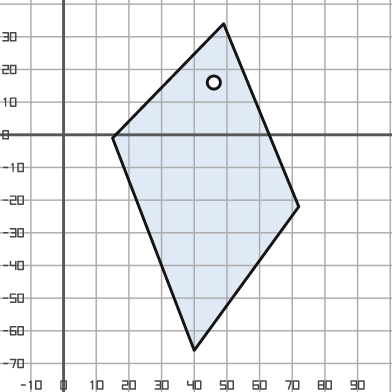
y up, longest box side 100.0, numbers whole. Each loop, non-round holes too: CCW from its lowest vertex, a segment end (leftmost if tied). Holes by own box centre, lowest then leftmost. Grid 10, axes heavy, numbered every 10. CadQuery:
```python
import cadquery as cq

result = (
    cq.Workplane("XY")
    .moveTo(40.0, -66.0)
    .lineTo(72.0, -22.0)
    .lineTo(49.0, 34.0)
    .lineTo(15.0, -1.0)
    .close()
    .moveTo(46.0, 16.0)
    .circle(2.0)
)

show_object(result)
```